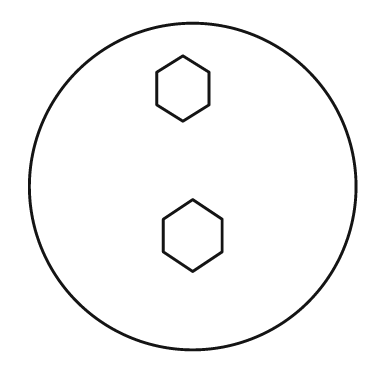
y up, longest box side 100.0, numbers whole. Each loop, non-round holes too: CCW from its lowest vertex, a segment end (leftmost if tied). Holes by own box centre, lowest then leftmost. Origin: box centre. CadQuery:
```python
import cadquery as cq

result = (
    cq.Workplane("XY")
    .moveTo(0.0, 0.0)
    .circle(50.0)
    .moveTo(0.0, -26.0)
    .lineTo(9.0, -20.0)
    .lineTo(9.0, -10.0)
    .lineTo(0.0, -4.0)
    .lineTo(-9.0, -10.0)
    .lineTo(-9.0, -20.0)
    .close()
    .moveTo(-3.0, 20.0)
    .lineTo(5.0, 25.0)
    .lineTo(5.0, 35.0)
    .lineTo(-3.0, 40.0)
    .lineTo(-11.0, 35.0)
    .lineTo(-11.0, 25.0)
    .close()
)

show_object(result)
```